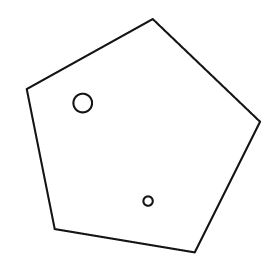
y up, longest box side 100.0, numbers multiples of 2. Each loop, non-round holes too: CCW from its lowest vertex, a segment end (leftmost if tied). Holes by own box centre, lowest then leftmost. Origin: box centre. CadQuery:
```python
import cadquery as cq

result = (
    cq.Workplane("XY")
    .moveTo(22.0, -50.0)
    .lineTo(50.0, 6.0)
    .lineTo(4.0, 50.0)
    .lineTo(-50.0, 20.0)
    .lineTo(-38.0, -40.0)
    .close()
    .moveTo(2.0, -28.0)
    .circle(2.0)
    .moveTo(-26.0, 14.0)
    .circle(4.0)
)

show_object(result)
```